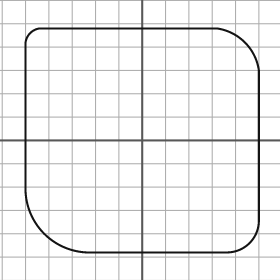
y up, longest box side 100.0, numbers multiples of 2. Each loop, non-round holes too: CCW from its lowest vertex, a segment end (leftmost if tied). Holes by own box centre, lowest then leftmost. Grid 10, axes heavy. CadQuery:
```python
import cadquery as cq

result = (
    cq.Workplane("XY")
    .moveTo(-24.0, -48.0)
    .lineTo(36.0, -48.0)
    .threePointArc((46.0, -44.0), (50.0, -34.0))
    .lineTo(50.0, 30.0)
    .threePointArc((44.0, 42.0), (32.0, 48.0))
    .lineTo(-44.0, 48.0)
    .threePointArc((-48.0, 46.0), (-50.0, 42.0))
    .lineTo(-50.0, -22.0)
    .threePointArc((-42.0, -40.0), (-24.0, -48.0))
    .close()
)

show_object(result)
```